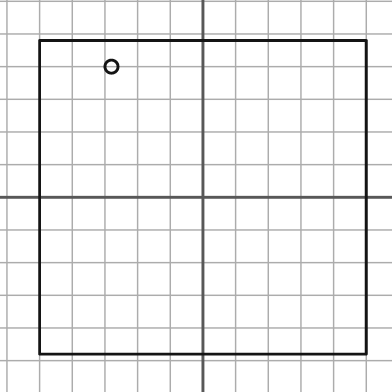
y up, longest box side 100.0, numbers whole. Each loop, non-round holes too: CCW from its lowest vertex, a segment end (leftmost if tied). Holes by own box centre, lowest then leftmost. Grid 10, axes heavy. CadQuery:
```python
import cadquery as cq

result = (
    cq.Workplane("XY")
    .moveTo(-50.0, -48.0)
    .lineTo(50.0, -48.0)
    .lineTo(50.0, 48.0)
    .lineTo(-50.0, 48.0)
    .close()
    .moveTo(-28.0, 40.0)
    .circle(2.0)
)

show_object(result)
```